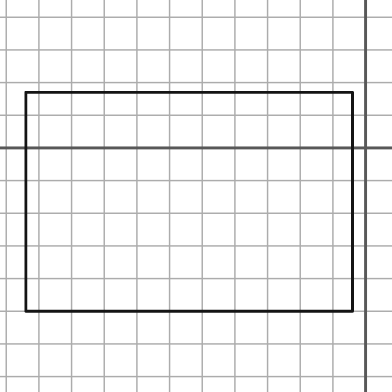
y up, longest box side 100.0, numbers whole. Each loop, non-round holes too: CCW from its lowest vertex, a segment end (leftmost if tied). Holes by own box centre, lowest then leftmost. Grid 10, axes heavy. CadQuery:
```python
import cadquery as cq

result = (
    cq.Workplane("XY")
    .moveTo(-104.0, -50.0)
    .lineTo(-4.0, -50.0)
    .lineTo(-4.0, 17.0)
    .lineTo(-104.0, 17.0)
    .close()
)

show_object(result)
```